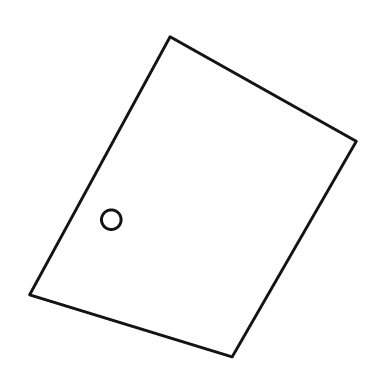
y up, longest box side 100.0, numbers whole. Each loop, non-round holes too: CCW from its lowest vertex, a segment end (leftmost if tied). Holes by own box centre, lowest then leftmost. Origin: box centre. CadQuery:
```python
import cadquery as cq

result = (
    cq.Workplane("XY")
    .moveTo(12.0, -49.0)
    .lineTo(50.0, 17.0)
    .lineTo(-7.0, 49.0)
    .lineTo(-50.0, -30.0)
    .close()
    .moveTo(-25.0, -7.0)
    .circle(3.0)
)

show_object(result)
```